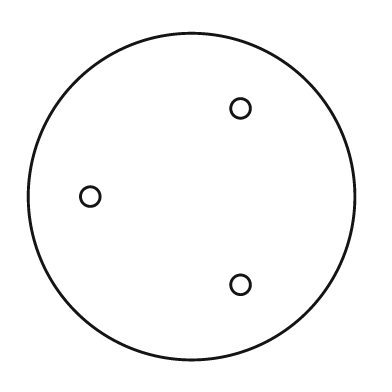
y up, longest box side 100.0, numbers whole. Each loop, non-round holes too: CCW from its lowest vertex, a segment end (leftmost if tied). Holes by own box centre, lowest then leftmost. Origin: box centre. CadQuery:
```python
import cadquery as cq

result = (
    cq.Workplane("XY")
    .moveTo(0.0, 0.0)
    .circle(50.0)
    .moveTo(15.0, -27.0)
    .circle(3.0)
    .moveTo(-31.0, 0.0)
    .circle(3.0)
    .moveTo(15.0, 27.0)
    .circle(3.0)
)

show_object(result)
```